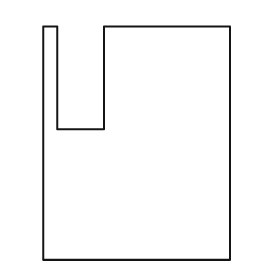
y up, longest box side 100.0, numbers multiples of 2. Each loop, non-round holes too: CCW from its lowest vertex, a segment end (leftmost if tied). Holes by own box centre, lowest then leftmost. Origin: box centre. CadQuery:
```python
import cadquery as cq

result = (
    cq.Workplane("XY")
    .moveTo(-40.0, -50.0)
    .lineTo(40.0, -50.0)
    .lineTo(40.0, 50.0)
    .lineTo(-14.0, 50.0)
    .lineTo(-14.0, 6.0)
    .lineTo(-34.0, 6.0)
    .lineTo(-34.0, 50.0)
    .lineTo(-40.0, 50.0)
    .close()
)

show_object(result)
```